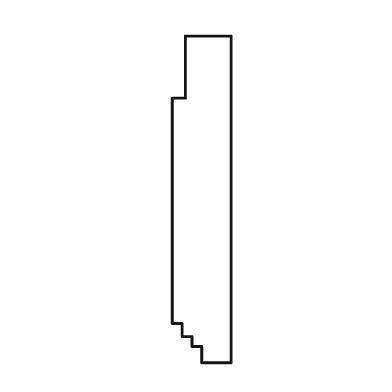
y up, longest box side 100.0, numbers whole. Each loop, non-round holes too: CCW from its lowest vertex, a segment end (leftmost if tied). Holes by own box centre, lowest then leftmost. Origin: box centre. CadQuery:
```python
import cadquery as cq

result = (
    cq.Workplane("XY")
    .moveTo(0.0, -50.0)
    .lineTo(9.0, -50.0)
    .lineTo(9.0, 50.0)
    .lineTo(-5.0, 50.0)
    .lineTo(-5.0, 31.0)
    .lineTo(-9.0, 31.0)
    .lineTo(-9.0, -38.0)
    .lineTo(-6.0, -38.0)
    .lineTo(-6.0, -42.0)
    .lineTo(-3.0, -42.0)
    .lineTo(-3.0, -45.0)
    .lineTo(0.0, -45.0)
    .close()
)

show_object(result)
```